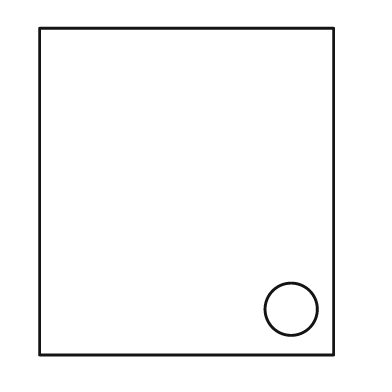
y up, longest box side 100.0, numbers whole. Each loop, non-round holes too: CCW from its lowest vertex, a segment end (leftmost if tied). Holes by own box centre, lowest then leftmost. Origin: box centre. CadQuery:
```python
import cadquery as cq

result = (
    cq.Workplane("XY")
    .moveTo(-45.0, -50.0)
    .lineTo(45.0, -50.0)
    .lineTo(45.0, 50.0)
    .lineTo(-45.0, 50.0)
    .close()
    .moveTo(32.0, -36.0)
    .circle(8.0)
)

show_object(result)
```